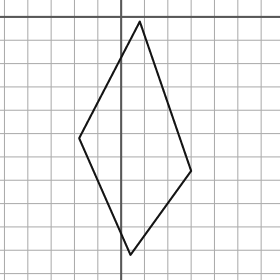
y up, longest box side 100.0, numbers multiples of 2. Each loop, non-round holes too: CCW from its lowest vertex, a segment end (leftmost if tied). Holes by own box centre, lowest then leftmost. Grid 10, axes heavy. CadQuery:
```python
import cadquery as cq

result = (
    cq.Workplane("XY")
    .moveTo(4.0, -102.0)
    .lineTo(30.0, -66.0)
    .lineTo(8.0, -2.0)
    .lineTo(-18.0, -52.0)
    .close()
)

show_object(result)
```